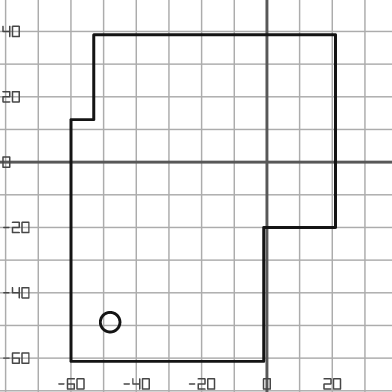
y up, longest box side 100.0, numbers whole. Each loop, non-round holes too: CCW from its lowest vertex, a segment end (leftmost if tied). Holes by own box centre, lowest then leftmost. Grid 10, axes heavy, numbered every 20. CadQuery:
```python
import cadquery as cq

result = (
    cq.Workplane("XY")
    .moveTo(-60.0, -61.0)
    .lineTo(-1.0, -61.0)
    .lineTo(-1.0, -20.0)
    .lineTo(21.0, -20.0)
    .lineTo(21.0, 39.0)
    .lineTo(-53.0, 39.0)
    .lineTo(-53.0, 13.0)
    .lineTo(-60.0, 13.0)
    .close()
    .moveTo(-48.0, -49.0)
    .circle(3.0)
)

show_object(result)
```